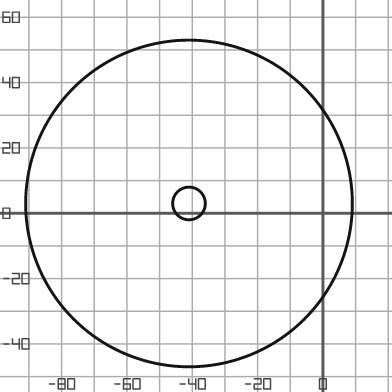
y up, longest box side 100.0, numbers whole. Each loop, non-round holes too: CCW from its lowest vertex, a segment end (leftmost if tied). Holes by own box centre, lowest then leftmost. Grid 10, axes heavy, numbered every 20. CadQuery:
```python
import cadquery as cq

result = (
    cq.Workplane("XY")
    .moveTo(-41.0, 3.0)
    .circle(50.0)
    .moveTo(-41.0, 3.0)
    .circle(5.0)
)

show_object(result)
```